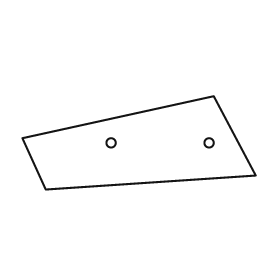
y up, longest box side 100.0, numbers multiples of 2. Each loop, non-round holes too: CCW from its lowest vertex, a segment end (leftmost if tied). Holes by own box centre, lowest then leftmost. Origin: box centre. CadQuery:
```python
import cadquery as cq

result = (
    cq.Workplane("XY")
    .moveTo(-40.0, -20.0)
    .lineTo(50.0, -14.0)
    .lineTo(32.0, 20.0)
    .lineTo(-50.0, 2.0)
    .close()
    .moveTo(-12.0, 0.0)
    .circle(2.0)
    .moveTo(30.0, 0.0)
    .circle(2.0)
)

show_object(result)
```